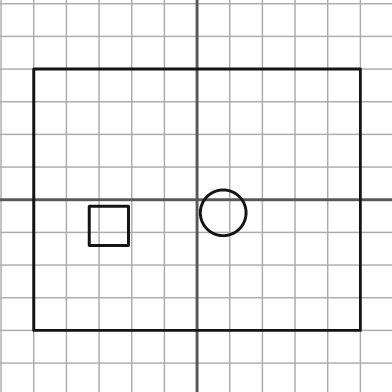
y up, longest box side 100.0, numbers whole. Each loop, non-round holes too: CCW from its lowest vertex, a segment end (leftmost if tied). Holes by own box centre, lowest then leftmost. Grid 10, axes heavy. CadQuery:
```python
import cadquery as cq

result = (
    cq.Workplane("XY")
    .moveTo(-50.0, -40.0)
    .lineTo(50.0, -40.0)
    .lineTo(50.0, 40.0)
    .lineTo(-50.0, 40.0)
    .close()
    .moveTo(-33.0, -14.0)
    .lineTo(-21.0, -14.0)
    .lineTo(-21.0, -2.0)
    .lineTo(-33.0, -2.0)
    .close()
    .moveTo(8.0, -4.0)
    .circle(7.0)
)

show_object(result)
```